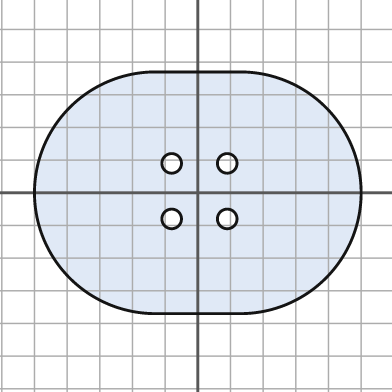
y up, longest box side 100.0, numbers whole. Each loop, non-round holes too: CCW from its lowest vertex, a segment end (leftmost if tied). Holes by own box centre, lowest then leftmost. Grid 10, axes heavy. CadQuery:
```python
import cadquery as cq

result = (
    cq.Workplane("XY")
    .moveTo(-13.0, -37.0)
    .lineTo(13.0, -37.0)
    .threePointArc((50.0, 0.0), (13.0, 37.0))
    .lineTo(-13.0, 37.0)
    .threePointArc((-50.0, 0.0), (-13.0, -37.0))
    .close()
    .moveTo(-8.0, -8.0)
    .circle(3.0)
    .moveTo(9.0, -8.0)
    .circle(3.0)
    .moveTo(-8.0, 9.0)
    .circle(3.0)
    .moveTo(9.0, 9.0)
    .circle(3.0)
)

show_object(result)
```